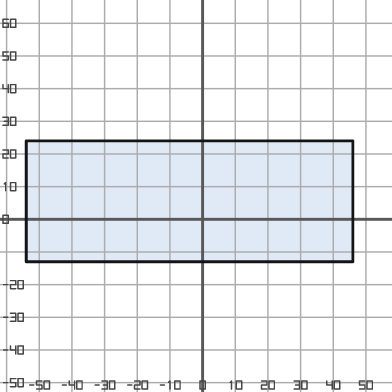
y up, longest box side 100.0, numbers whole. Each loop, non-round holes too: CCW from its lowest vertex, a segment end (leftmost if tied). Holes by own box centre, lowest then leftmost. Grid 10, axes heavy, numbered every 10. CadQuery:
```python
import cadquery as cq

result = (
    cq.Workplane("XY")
    .moveTo(-54.0, -13.0)
    .lineTo(46.0, -13.0)
    .lineTo(46.0, 24.0)
    .lineTo(-54.0, 24.0)
    .close()
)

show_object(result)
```